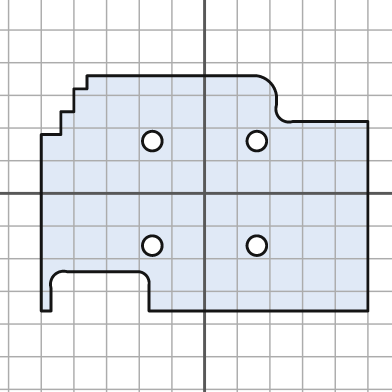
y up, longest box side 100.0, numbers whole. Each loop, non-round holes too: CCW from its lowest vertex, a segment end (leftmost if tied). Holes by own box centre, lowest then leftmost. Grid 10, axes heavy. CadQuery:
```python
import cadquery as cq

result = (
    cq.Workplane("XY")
    .moveTo(-50.0, -36.0)
    .lineTo(-47.0, -36.0)
    .lineTo(-47.0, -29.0)
    .threePointArc((-46.0, -25.0), (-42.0, -24.0))
    .lineTo(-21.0, -24.0)
    .threePointArc((-18.0, -25.0), (-17.0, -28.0))
    .lineTo(-17.0, -36.0)
    .lineTo(50.0, -36.0)
    .lineTo(50.0, 22.0)
    .lineTo(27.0, 22.0)
    .threePointArc((23.0, 23.0), (22.0, 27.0))
    .lineTo(22.0, 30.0)
    .threePointArc((20.0, 34.0), (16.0, 36.0))
    .lineTo(-36.0, 36.0)
    .lineTo(-36.0, 32.0)
    .lineTo(-40.0, 32.0)
    .lineTo(-40.0, 25.0)
    .lineTo(-44.0, 25.0)
    .lineTo(-44.0, 18.0)
    .lineTo(-50.0, 18.0)
    .close()
    .moveTo(-16.0, -16.0)
    .circle(3.0)
    .moveTo(16.0, -16.0)
    .circle(3.0)
    .moveTo(-16.0, 16.0)
    .circle(3.0)
    .moveTo(16.0, 16.0)
    .circle(3.0)
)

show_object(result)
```